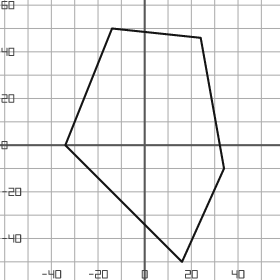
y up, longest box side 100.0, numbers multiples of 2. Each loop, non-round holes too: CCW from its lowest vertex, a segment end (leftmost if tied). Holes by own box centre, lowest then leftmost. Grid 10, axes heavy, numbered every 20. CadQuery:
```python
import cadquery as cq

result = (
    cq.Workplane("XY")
    .moveTo(16.0, -50.0)
    .lineTo(34.0, -10.0)
    .lineTo(24.0, 46.0)
    .lineTo(-14.0, 50.0)
    .lineTo(-34.0, 0.0)
    .close()
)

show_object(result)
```